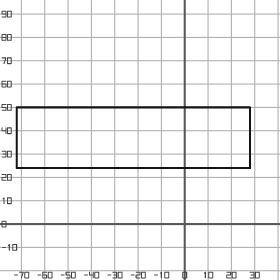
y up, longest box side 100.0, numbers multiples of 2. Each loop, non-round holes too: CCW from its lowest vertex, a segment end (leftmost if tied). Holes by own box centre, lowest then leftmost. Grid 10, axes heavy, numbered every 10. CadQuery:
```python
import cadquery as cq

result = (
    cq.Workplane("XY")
    .moveTo(-72.0, 24.0)
    .lineTo(28.0, 24.0)
    .lineTo(28.0, 50.0)
    .lineTo(-72.0, 50.0)
    .close()
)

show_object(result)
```